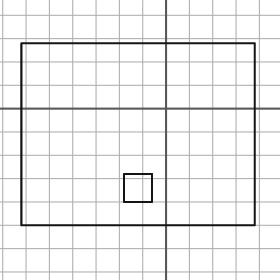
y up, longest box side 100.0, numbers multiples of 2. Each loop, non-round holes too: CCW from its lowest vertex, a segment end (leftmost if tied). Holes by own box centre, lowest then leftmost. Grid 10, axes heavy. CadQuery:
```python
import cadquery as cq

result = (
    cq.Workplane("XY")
    .moveTo(-62.0, -50.0)
    .lineTo(38.0, -50.0)
    .lineTo(38.0, 28.0)
    .lineTo(-62.0, 28.0)
    .close()
    .moveTo(-18.0, -40.0)
    .lineTo(-6.0, -40.0)
    .lineTo(-6.0, -28.0)
    .lineTo(-18.0, -28.0)
    .close()
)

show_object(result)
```